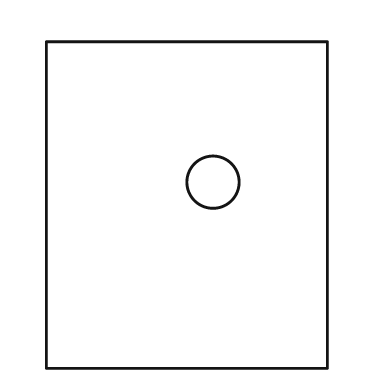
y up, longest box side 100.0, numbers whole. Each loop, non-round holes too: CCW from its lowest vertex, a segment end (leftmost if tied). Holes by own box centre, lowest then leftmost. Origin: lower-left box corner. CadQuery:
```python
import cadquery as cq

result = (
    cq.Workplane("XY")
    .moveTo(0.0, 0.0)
    .lineTo(86.0, 0.0)
    .lineTo(86.0, 100.0)
    .lineTo(0.0, 100.0)
    .close()
    .moveTo(51.0, 57.0)
    .circle(8.0)
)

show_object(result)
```